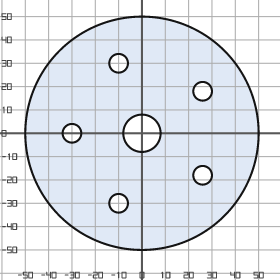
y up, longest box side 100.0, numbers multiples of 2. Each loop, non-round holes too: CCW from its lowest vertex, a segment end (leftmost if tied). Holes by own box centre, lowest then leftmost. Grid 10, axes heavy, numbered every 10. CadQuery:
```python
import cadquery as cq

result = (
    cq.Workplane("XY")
    .moveTo(0.0, 0.0)
    .circle(50.0)
    .moveTo(-10.0, -30.0)
    .circle(4.0)
    .moveTo(26.0, -18.0)
    .circle(4.0)
    .moveTo(-30.0, 0.0)
    .circle(4.0)
    .moveTo(0.0, 0.0)
    .circle(8.0)
    .moveTo(26.0, 18.0)
    .circle(4.0)
    .moveTo(-10.0, 30.0)
    .circle(4.0)
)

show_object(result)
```